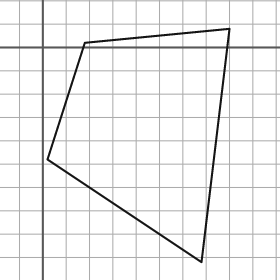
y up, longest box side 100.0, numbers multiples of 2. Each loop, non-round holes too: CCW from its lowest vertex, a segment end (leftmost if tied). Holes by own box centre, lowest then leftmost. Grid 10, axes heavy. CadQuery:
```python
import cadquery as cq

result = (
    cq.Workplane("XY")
    .moveTo(68.0, -92.0)
    .lineTo(80.0, 8.0)
    .lineTo(18.0, 2.0)
    .lineTo(2.0, -48.0)
    .close()
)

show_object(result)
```